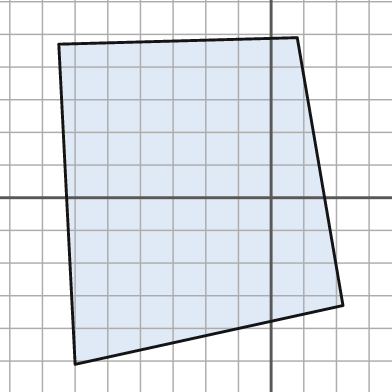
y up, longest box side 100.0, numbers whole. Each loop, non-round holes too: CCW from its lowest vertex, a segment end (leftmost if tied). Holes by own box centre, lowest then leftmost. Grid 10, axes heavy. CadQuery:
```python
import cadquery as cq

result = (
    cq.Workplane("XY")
    .moveTo(-60.0, -51.0)
    .lineTo(22.0, -33.0)
    .lineTo(8.0, 49.0)
    .lineTo(-65.0, 47.0)
    .close()
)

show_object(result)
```